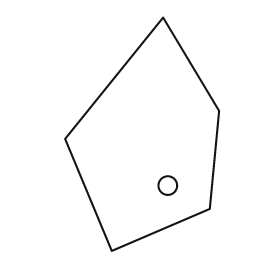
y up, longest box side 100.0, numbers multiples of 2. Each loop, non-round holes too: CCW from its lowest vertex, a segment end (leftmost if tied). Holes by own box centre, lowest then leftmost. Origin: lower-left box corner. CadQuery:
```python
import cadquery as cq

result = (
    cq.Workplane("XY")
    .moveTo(20.0, 0.0)
    .lineTo(62.0, 18.0)
    .lineTo(66.0, 60.0)
    .lineTo(42.0, 100.0)
    .lineTo(0.0, 48.0)
    .close()
    .moveTo(44.0, 28.0)
    .circle(4.0)
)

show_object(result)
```